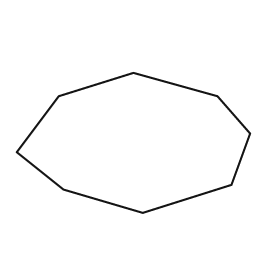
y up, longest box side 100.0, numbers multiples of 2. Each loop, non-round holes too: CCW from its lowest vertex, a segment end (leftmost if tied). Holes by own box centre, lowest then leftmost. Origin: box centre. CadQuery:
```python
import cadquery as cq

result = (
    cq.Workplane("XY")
    .moveTo(4.0, -30.0)
    .lineTo(42.0, -18.0)
    .lineTo(50.0, 4.0)
    .lineTo(36.0, 20.0)
    .lineTo(0.0, 30.0)
    .lineTo(-32.0, 20.0)
    .lineTo(-50.0, -4.0)
    .lineTo(-30.0, -20.0)
    .close()
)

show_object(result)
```